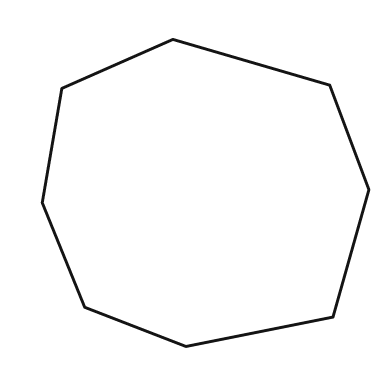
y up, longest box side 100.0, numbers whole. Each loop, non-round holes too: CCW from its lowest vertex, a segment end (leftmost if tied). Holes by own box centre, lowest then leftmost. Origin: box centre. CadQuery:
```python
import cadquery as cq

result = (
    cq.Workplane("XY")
    .moveTo(-6.0, -47.0)
    .lineTo(39.0, -38.0)
    .lineTo(50.0, 1.0)
    .lineTo(38.0, 33.0)
    .lineTo(-10.0, 47.0)
    .lineTo(-44.0, 32.0)
    .lineTo(-50.0, -3.0)
    .lineTo(-37.0, -35.0)
    .close()
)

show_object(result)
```